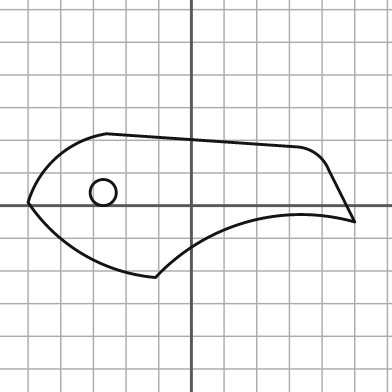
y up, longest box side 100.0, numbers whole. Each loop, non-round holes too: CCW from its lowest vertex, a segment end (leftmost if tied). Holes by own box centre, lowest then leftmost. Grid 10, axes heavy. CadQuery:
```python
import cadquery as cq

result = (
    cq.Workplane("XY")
    .moveTo(-11.0, -22.0)
    .threePointArc((17.0, -5.0), (50.0, -5.0))
    .lineTo(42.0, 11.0)
    .threePointArc((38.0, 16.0), (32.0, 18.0))
    .lineTo(-26.0, 22.0)
    .threePointArc((-41.0, 15.0), (-50.0, 1.0))
    .threePointArc((-33.0, -15.0), (-11.0, -22.0))
    .close()
    .moveTo(-27.0, 4.0)
    .circle(4.0)
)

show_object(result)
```